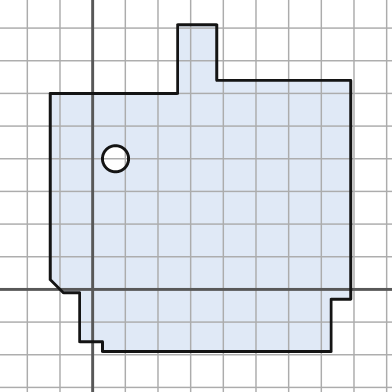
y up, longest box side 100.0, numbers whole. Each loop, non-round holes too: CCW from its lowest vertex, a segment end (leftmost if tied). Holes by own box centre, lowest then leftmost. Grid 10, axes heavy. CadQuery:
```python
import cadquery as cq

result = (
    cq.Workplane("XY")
    .moveTo(3.0, -19.0)
    .lineTo(73.0, -19.0)
    .lineTo(73.0, -3.0)
    .lineTo(79.0, -3.0)
    .lineTo(79.0, 64.0)
    .lineTo(38.0, 64.0)
    .lineTo(38.0, 81.0)
    .lineTo(26.0, 81.0)
    .lineTo(26.0, 60.0)
    .lineTo(-13.0, 60.0)
    .lineTo(-13.0, 3.0)
    .lineTo(-9.0, -1.0)
    .lineTo(-4.0, -1.0)
    .lineTo(-4.0, -16.0)
    .lineTo(3.0, -16.0)
    .close()
    .moveTo(7.0, 40.0)
    .circle(4.0)
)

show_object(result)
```